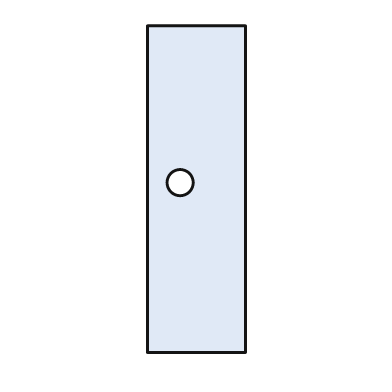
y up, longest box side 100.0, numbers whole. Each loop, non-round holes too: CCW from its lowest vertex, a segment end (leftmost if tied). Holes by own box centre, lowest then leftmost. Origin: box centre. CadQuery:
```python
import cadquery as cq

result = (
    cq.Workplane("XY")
    .moveTo(-15.0, -50.0)
    .lineTo(15.0, -50.0)
    .lineTo(15.0, 50.0)
    .lineTo(-15.0, 50.0)
    .close()
    .moveTo(-5.0, 2.0)
    .circle(4.0)
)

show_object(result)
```